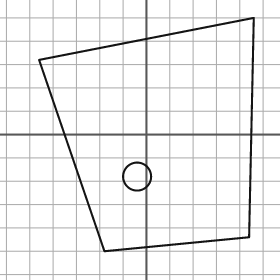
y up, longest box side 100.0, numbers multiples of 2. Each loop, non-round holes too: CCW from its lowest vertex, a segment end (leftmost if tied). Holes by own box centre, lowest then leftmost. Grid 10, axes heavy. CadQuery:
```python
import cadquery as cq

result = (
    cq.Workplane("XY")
    .moveTo(-18.0, -50.0)
    .lineTo(44.0, -44.0)
    .lineTo(46.0, 50.0)
    .lineTo(-46.0, 32.0)
    .close()
    .moveTo(-4.0, -18.0)
    .circle(6.0)
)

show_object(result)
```